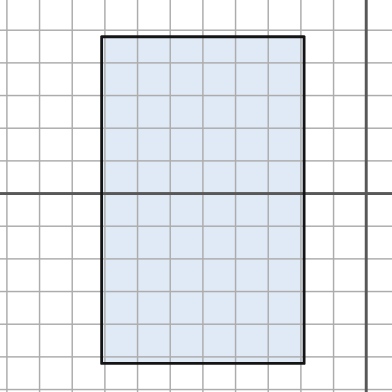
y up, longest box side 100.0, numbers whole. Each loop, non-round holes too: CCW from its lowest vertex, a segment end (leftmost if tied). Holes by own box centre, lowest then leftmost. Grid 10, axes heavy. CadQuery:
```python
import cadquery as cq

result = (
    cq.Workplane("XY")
    .moveTo(-81.0, -52.0)
    .lineTo(-19.0, -52.0)
    .lineTo(-19.0, 48.0)
    .lineTo(-81.0, 48.0)
    .close()
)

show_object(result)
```